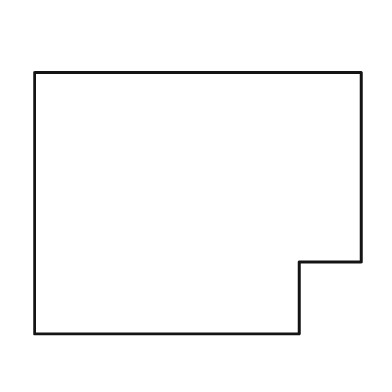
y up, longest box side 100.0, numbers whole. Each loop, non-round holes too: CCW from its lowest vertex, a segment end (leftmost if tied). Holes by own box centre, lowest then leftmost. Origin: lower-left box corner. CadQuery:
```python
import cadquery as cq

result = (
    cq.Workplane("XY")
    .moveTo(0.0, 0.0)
    .lineTo(81.0, 0.0)
    .lineTo(81.0, 22.0)
    .lineTo(100.0, 22.0)
    .lineTo(100.0, 80.0)
    .lineTo(0.0, 80.0)
    .close()
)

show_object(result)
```